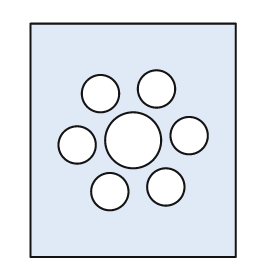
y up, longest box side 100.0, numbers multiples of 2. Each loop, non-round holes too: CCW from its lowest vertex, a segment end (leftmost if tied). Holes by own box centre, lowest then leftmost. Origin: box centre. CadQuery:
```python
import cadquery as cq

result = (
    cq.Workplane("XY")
    .moveTo(-44.0, -50.0)
    .lineTo(44.0, -50.0)
    .lineTo(44.0, 50.0)
    .lineTo(-44.0, 50.0)
    .close()
    .moveTo(-10.0, -22.0)
    .circle(8.0)
    .moveTo(14.0, -20.0)
    .circle(8.0)
    .moveTo(-24.0, -2.0)
    .circle(8.0)
    .moveTo(0.0, 0.0)
    .circle(12.0)
    .moveTo(24.0, 2.0)
    .circle(8.0)
    .moveTo(-14.0, 20.0)
    .circle(8.0)
    .moveTo(10.0, 22.0)
    .circle(8.0)
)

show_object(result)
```